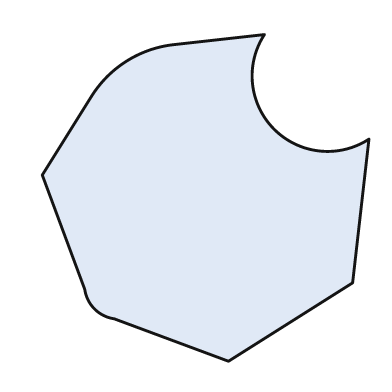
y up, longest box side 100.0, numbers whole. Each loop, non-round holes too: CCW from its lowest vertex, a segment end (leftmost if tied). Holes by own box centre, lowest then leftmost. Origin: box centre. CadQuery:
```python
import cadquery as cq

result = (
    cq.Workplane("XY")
    .moveTo(7.0, -50.0)
    .lineTo(45.0, -26.0)
    .lineTo(50.0, 18.0)
    .threePointArc((21.0, 21.0), (18.0, 50.0))
    .lineTo(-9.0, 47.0)
    .threePointArc((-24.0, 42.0), (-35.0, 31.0))
    .lineTo(-50.0, 7.0)
    .lineTo(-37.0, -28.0)
    .threePointArc((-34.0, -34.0), (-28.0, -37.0))
    .close()
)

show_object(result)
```